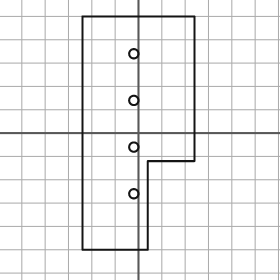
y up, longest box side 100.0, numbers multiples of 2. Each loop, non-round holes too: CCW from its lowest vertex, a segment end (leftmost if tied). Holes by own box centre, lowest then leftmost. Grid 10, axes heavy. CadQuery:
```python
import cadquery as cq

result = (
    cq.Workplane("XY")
    .moveTo(-24.0, -50.0)
    .lineTo(4.0, -50.0)
    .lineTo(4.0, -12.0)
    .lineTo(24.0, -12.0)
    .lineTo(24.0, 50.0)
    .lineTo(-24.0, 50.0)
    .close()
    .moveTo(-2.0, -26.0)
    .circle(2.0)
    .moveTo(-2.0, -6.0)
    .circle(2.0)
    .moveTo(-2.0, 14.0)
    .circle(2.0)
    .moveTo(-2.0, 34.0)
    .circle(2.0)
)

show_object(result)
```